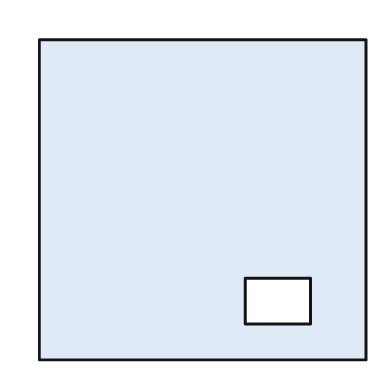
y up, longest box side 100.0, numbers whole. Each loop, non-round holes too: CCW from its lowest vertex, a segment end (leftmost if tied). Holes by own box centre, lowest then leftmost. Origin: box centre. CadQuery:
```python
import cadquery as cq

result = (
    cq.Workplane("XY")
    .moveTo(-50.0, -49.0)
    .lineTo(50.0, -49.0)
    .lineTo(50.0, 49.0)
    .lineTo(-50.0, 49.0)
    .close()
    .moveTo(13.0, -38.0)
    .lineTo(33.0, -38.0)
    .lineTo(33.0, -24.0)
    .lineTo(13.0, -24.0)
    .close()
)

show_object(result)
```